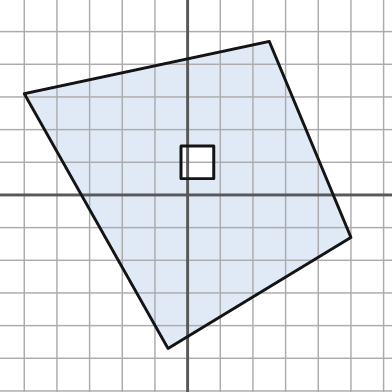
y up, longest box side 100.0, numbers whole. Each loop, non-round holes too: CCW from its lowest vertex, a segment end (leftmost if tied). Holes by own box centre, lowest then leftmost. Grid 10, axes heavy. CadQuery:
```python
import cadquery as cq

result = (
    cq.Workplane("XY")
    .moveTo(-6.0, -47.0)
    .lineTo(50.0, -13.0)
    .lineTo(25.0, 47.0)
    .lineTo(-50.0, 31.0)
    .close()
    .moveTo(-2.0, 5.0)
    .lineTo(8.0, 5.0)
    .lineTo(8.0, 15.0)
    .lineTo(-2.0, 15.0)
    .close()
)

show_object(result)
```